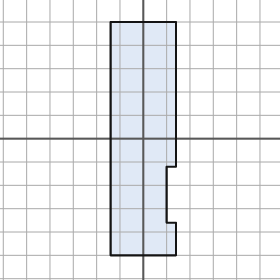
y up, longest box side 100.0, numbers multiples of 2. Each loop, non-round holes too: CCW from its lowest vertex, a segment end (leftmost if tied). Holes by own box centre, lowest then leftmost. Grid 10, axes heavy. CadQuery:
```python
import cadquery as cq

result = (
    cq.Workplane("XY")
    .moveTo(-14.0, -50.0)
    .lineTo(14.0, -50.0)
    .lineTo(14.0, -36.0)
    .lineTo(10.0, -36.0)
    .lineTo(10.0, -12.0)
    .lineTo(14.0, -12.0)
    .lineTo(14.0, 50.0)
    .lineTo(-14.0, 50.0)
    .close()
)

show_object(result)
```